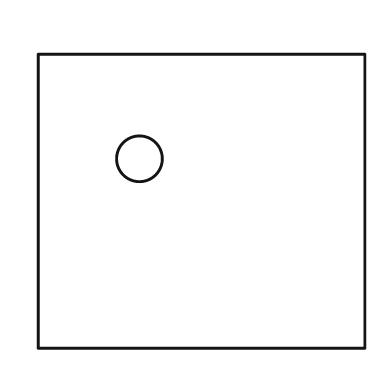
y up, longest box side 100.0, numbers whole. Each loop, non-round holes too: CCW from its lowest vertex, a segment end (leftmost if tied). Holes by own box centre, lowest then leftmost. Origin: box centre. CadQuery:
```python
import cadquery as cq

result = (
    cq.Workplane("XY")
    .moveTo(-50.0, -45.0)
    .lineTo(50.0, -45.0)
    .lineTo(50.0, 45.0)
    .lineTo(-50.0, 45.0)
    .close()
    .moveTo(-19.0, 13.0)
    .circle(7.0)
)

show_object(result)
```